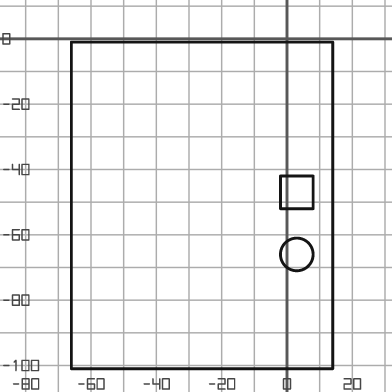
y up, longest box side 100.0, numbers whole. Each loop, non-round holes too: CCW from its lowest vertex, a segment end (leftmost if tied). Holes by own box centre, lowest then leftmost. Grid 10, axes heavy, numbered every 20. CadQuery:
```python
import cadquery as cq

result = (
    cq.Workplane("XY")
    .moveTo(-66.0, -101.0)
    .lineTo(14.0, -101.0)
    .lineTo(14.0, -1.0)
    .lineTo(-66.0, -1.0)
    .close()
    .moveTo(3.0, -66.0)
    .circle(5.0)
    .moveTo(-2.0, -52.0)
    .lineTo(8.0, -52.0)
    .lineTo(8.0, -42.0)
    .lineTo(-2.0, -42.0)
    .close()
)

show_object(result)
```